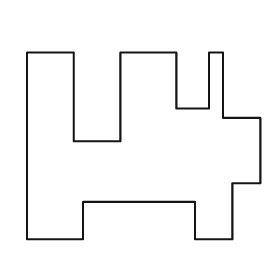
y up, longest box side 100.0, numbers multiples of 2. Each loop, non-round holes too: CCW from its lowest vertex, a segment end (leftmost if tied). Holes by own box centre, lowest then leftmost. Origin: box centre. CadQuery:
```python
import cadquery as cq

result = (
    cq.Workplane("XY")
    .moveTo(-50.0, -40.0)
    .lineTo(-26.0, -40.0)
    .lineTo(-26.0, -24.0)
    .lineTo(22.0, -24.0)
    .lineTo(22.0, -40.0)
    .lineTo(38.0, -40.0)
    .lineTo(38.0, -16.0)
    .lineTo(50.0, -16.0)
    .lineTo(50.0, 12.0)
    .lineTo(34.0, 12.0)
    .lineTo(34.0, 40.0)
    .lineTo(28.0, 40.0)
    .lineTo(28.0, 16.0)
    .lineTo(14.0, 16.0)
    .lineTo(14.0, 40.0)
    .lineTo(-10.0, 40.0)
    .lineTo(-10.0, 2.0)
    .lineTo(-30.0, 2.0)
    .lineTo(-30.0, 40.0)
    .lineTo(-50.0, 40.0)
    .close()
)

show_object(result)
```